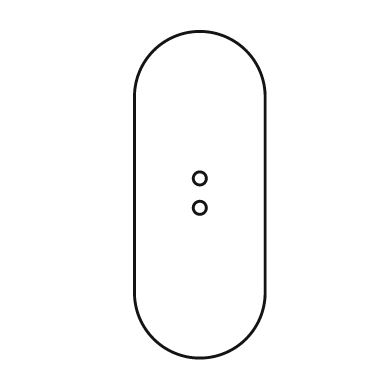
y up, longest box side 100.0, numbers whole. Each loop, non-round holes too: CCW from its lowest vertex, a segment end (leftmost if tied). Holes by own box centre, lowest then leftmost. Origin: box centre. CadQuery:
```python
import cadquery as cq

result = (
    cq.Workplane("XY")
    .moveTo(-20.0, -30.0)
    .threePointArc((0.0, -50.0), (20.0, -30.0))
    .lineTo(20.0, 30.0)
    .threePointArc((0.0, 50.0), (-20.0, 30.0))
    .close()
    .moveTo(0.0, -4.0)
    .circle(2.0)
    .moveTo(0.0, 5.0)
    .circle(2.0)
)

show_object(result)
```